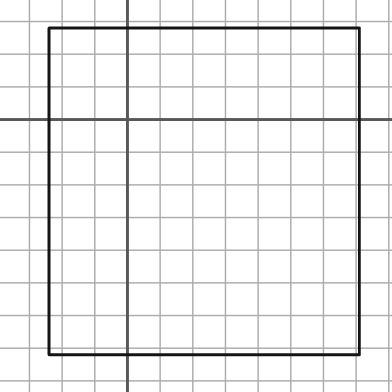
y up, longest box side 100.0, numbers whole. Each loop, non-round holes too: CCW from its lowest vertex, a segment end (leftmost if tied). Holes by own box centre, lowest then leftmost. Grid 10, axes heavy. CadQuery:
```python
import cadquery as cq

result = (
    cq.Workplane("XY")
    .moveTo(-24.0, -72.0)
    .lineTo(71.0, -72.0)
    .lineTo(71.0, 28.0)
    .lineTo(-24.0, 28.0)
    .close()
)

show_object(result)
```